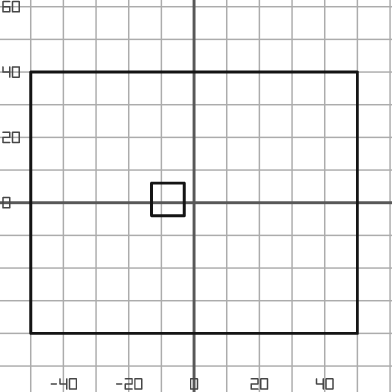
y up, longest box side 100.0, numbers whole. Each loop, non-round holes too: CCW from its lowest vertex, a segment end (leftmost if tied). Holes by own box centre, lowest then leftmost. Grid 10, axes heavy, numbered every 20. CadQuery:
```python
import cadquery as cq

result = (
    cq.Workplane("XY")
    .moveTo(-50.0, -40.0)
    .lineTo(50.0, -40.0)
    .lineTo(50.0, 40.0)
    .lineTo(-50.0, 40.0)
    .close()
    .moveTo(-13.0, -4.0)
    .lineTo(-3.0, -4.0)
    .lineTo(-3.0, 6.0)
    .lineTo(-13.0, 6.0)
    .close()
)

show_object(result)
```